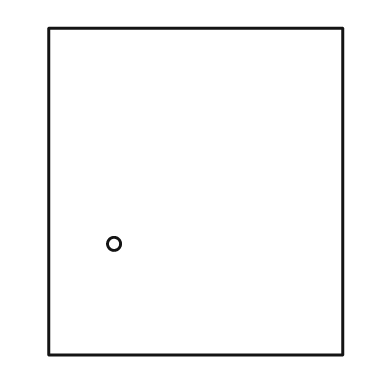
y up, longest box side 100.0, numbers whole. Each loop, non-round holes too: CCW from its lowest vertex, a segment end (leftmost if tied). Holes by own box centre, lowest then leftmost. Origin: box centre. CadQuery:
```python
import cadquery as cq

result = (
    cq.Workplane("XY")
    .moveTo(-45.0, -50.0)
    .lineTo(45.0, -50.0)
    .lineTo(45.0, 50.0)
    .lineTo(-45.0, 50.0)
    .close()
    .moveTo(-25.0, -16.0)
    .circle(2.0)
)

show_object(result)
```